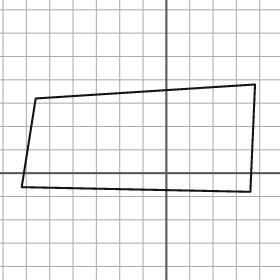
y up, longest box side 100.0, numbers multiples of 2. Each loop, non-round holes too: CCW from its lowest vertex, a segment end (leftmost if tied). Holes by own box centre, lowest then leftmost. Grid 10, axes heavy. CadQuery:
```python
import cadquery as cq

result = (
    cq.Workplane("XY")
    .moveTo(36.0, -8.0)
    .lineTo(38.0, 38.0)
    .lineTo(-56.0, 32.0)
    .lineTo(-62.0, -6.0)
    .close()
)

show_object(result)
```